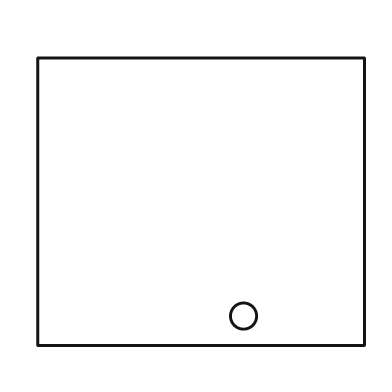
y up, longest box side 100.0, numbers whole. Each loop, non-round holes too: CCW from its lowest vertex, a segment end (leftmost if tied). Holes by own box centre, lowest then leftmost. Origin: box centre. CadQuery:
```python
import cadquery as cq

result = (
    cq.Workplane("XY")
    .moveTo(-50.0, -44.0)
    .lineTo(50.0, -44.0)
    .lineTo(50.0, 44.0)
    .lineTo(-50.0, 44.0)
    .close()
    .moveTo(13.0, -35.0)
    .circle(4.0)
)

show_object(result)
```